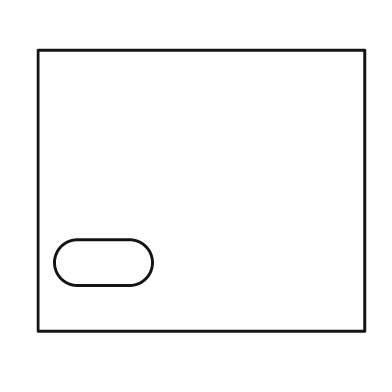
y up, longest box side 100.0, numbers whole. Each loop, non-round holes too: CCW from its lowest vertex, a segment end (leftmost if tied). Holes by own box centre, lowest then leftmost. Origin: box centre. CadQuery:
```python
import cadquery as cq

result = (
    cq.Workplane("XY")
    .moveTo(-50.0, -43.0)
    .lineTo(50.0, -43.0)
    .lineTo(50.0, 43.0)
    .lineTo(-50.0, 43.0)
    .close()
    .moveTo(-38.0, -29.0)
    .lineTo(-22.0, -29.0)
    .threePointArc((-15.0, -22.0), (-22.0, -15.0))
    .lineTo(-38.0, -15.0)
    .threePointArc((-45.0, -22.0), (-38.0, -29.0))
    .close()
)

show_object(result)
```